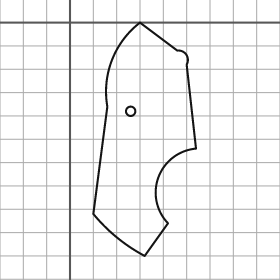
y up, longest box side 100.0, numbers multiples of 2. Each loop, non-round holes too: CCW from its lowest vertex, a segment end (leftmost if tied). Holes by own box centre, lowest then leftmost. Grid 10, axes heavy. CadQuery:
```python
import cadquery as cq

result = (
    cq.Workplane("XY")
    .moveTo(32.0, -100.0)
    .lineTo(42.0, -86.0)
    .threePointArc((38.0, -66.0), (54.0, -54.0))
    .lineTo(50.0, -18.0)
    .threePointArc((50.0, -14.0), (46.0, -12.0))
    .lineTo(30.0, 0.0)
    .threePointArc((18.0, -16.0), (16.0, -36.0))
    .lineTo(10.0, -82.0)
    .threePointArc((20.0, -92.0), (32.0, -100.0))
    .close()
    .moveTo(26.0, -38.0)
    .circle(2.0)
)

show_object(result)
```